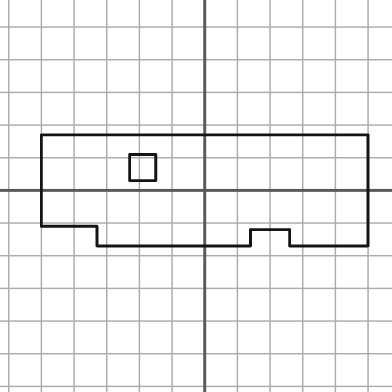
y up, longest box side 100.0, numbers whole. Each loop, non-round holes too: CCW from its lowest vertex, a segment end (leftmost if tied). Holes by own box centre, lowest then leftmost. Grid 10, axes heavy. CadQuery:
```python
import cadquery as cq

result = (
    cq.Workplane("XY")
    .moveTo(-33.0, -17.0)
    .lineTo(14.0, -17.0)
    .lineTo(14.0, -12.0)
    .lineTo(26.0, -12.0)
    .lineTo(26.0, -17.0)
    .lineTo(50.0, -17.0)
    .lineTo(50.0, 17.0)
    .lineTo(-50.0, 17.0)
    .lineTo(-50.0, -11.0)
    .lineTo(-33.0, -11.0)
    .close()
    .moveTo(-23.0, 3.0)
    .lineTo(-15.0, 3.0)
    .lineTo(-15.0, 11.0)
    .lineTo(-23.0, 11.0)
    .close()
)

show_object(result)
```